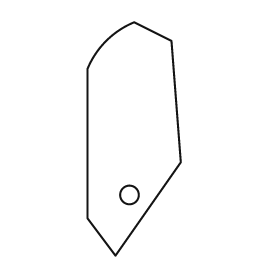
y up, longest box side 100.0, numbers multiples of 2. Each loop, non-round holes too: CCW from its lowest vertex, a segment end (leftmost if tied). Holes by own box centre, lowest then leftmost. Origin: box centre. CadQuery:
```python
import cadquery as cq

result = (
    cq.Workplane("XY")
    .moveTo(-8.0, -50.0)
    .lineTo(20.0, -10.0)
    .lineTo(16.0, 42.0)
    .lineTo(0.0, 50.0)
    .threePointArc((-12.0, 42.0), (-20.0, 30.0))
    .lineTo(-20.0, -34.0)
    .close()
    .moveTo(-2.0, -24.0)
    .circle(4.0)
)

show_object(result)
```